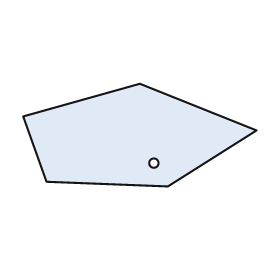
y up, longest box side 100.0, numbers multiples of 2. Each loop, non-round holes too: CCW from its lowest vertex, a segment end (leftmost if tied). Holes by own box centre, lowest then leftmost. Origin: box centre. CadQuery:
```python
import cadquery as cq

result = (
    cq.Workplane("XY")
    .moveTo(12.0, -22.0)
    .lineTo(50.0, 2.0)
    .lineTo(0.0, 22.0)
    .lineTo(-50.0, 8.0)
    .lineTo(-40.0, -20.0)
    .close()
    .moveTo(6.0, -12.0)
    .circle(2.0)
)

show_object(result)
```